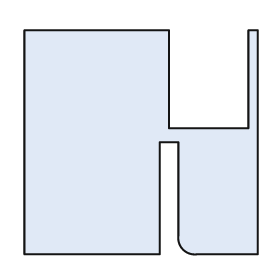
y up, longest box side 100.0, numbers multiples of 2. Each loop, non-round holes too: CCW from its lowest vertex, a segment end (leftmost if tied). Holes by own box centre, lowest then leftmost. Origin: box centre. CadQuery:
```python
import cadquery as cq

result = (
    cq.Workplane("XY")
    .moveTo(-50.0, -48.0)
    .lineTo(8.0, -48.0)
    .lineTo(8.0, 0.0)
    .lineTo(16.0, 0.0)
    .lineTo(16.0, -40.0)
    .threePointArc((18.0, -46.0), (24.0, -48.0))
    .lineTo(50.0, -48.0)
    .lineTo(50.0, 48.0)
    .lineTo(46.0, 48.0)
    .lineTo(46.0, 6.0)
    .lineTo(12.0, 6.0)
    .lineTo(12.0, 48.0)
    .lineTo(-50.0, 48.0)
    .close()
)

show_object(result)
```